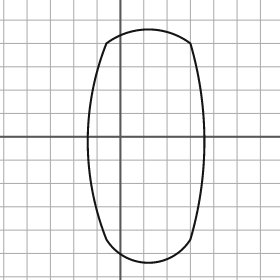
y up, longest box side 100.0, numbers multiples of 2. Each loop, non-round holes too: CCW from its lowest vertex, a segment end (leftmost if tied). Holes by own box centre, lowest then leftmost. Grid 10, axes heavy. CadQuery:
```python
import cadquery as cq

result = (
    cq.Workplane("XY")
    .moveTo(-6.0, -44.0)
    .threePointArc((12.0, -54.0), (30.0, -44.0))
    .threePointArc((36.0, -2.0), (30.0, 40.0))
    .threePointArc((12.0, 46.0), (-6.0, 40.0))
    .threePointArc((-14.0, -2.0), (-6.0, -44.0))
    .close()
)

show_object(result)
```